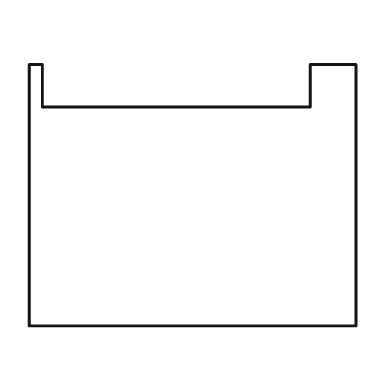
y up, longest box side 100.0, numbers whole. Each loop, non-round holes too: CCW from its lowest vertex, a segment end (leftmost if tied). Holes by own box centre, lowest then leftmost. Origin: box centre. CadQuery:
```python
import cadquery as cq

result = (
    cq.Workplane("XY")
    .moveTo(-50.0, -40.0)
    .lineTo(50.0, -40.0)
    .lineTo(50.0, 40.0)
    .lineTo(36.0, 40.0)
    .lineTo(36.0, 27.0)
    .lineTo(-46.0, 27.0)
    .lineTo(-46.0, 40.0)
    .lineTo(-50.0, 40.0)
    .close()
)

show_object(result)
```